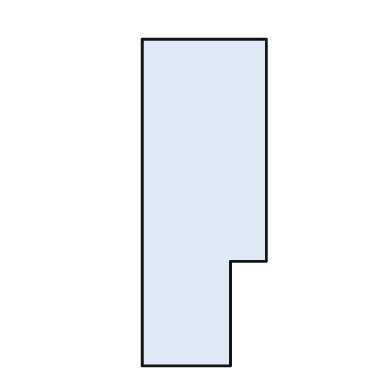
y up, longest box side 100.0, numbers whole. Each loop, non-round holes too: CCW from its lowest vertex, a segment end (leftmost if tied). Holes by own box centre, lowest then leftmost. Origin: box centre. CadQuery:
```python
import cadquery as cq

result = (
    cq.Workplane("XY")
    .moveTo(-19.0, -50.0)
    .lineTo(8.0, -50.0)
    .lineTo(8.0, -18.0)
    .lineTo(19.0, -18.0)
    .lineTo(19.0, 50.0)
    .lineTo(-19.0, 50.0)
    .close()
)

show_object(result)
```